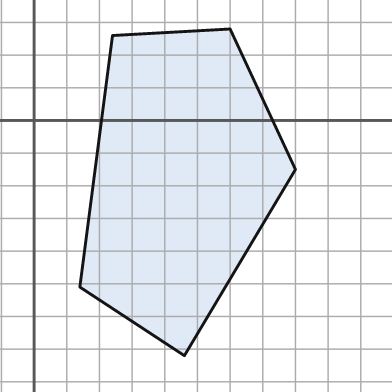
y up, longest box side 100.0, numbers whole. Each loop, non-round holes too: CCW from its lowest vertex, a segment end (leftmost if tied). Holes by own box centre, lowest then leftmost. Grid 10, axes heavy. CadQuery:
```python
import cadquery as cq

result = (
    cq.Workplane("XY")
    .moveTo(46.0, -72.0)
    .lineTo(80.0, -15.0)
    .lineTo(60.0, 28.0)
    .lineTo(24.0, 26.0)
    .lineTo(14.0, -51.0)
    .close()
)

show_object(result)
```